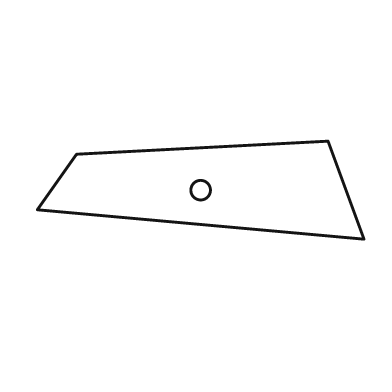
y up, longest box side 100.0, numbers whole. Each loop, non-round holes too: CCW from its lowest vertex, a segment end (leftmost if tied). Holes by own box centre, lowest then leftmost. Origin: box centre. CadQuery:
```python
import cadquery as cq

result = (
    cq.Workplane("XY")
    .moveTo(50.0, -15.0)
    .lineTo(39.0, 15.0)
    .lineTo(-38.0, 11.0)
    .lineTo(-50.0, -6.0)
    .close()
    .moveTo(0.0, 0.0)
    .circle(3.0)
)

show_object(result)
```